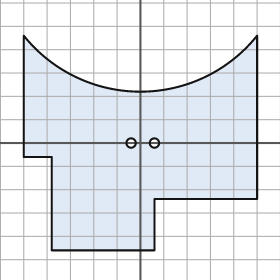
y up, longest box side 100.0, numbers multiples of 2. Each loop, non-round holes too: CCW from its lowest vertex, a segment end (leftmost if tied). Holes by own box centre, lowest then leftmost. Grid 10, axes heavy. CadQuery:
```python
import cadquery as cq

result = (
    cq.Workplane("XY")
    .moveTo(-38.0, -46.0)
    .lineTo(6.0, -46.0)
    .lineTo(6.0, -24.0)
    .lineTo(50.0, -24.0)
    .lineTo(50.0, 46.0)
    .threePointArc((0.0, 22.0), (-50.0, 46.0))
    .lineTo(-50.0, -6.0)
    .lineTo(-38.0, -6.0)
    .close()
    .moveTo(-4.0, 0.0)
    .circle(2.0)
    .moveTo(6.0, 0.0)
    .circle(2.0)
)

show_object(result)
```